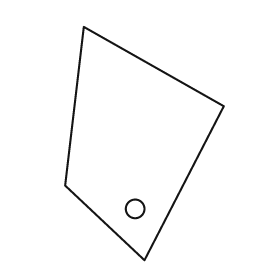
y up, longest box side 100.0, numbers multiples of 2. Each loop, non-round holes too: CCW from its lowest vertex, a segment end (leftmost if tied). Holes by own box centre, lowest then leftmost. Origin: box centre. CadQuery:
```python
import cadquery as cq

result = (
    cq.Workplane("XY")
    .moveTo(0.0, -50.0)
    .lineTo(34.0, 16.0)
    .lineTo(-26.0, 50.0)
    .lineTo(-34.0, -18.0)
    .close()
    .moveTo(-4.0, -28.0)
    .circle(4.0)
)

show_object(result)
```